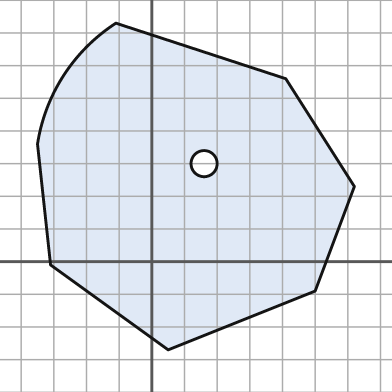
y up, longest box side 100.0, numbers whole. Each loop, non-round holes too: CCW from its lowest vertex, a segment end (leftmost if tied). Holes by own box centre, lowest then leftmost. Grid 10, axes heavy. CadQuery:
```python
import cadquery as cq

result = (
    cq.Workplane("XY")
    .moveTo(5.0, -27.0)
    .lineTo(50.0, -9.0)
    .lineTo(62.0, 23.0)
    .lineTo(41.0, 56.0)
    .lineTo(-11.0, 73.0)
    .threePointArc((-27.0, 57.0), (-35.0, 36.0))
    .lineTo(-31.0, -1.0)
    .close()
    .moveTo(16.0, 30.0)
    .circle(4.0)
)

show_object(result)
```